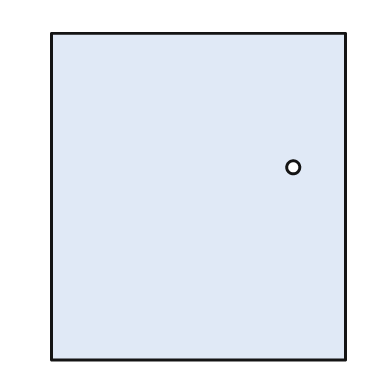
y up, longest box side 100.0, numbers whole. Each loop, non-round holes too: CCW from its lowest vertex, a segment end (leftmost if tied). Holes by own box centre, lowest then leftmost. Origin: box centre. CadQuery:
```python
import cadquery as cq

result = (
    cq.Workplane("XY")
    .moveTo(-45.0, -50.0)
    .lineTo(45.0, -50.0)
    .lineTo(45.0, 50.0)
    .lineTo(-45.0, 50.0)
    .close()
    .moveTo(29.0, 9.0)
    .circle(2.0)
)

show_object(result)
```